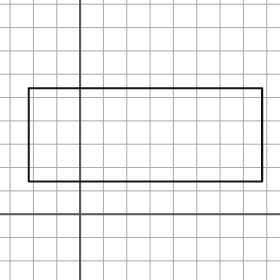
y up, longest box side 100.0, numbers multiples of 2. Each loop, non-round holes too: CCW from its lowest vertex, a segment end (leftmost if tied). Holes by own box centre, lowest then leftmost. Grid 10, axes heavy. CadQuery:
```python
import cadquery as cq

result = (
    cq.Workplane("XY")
    .moveTo(-22.0, 14.0)
    .lineTo(78.0, 14.0)
    .lineTo(78.0, 54.0)
    .lineTo(-22.0, 54.0)
    .close()
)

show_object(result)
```